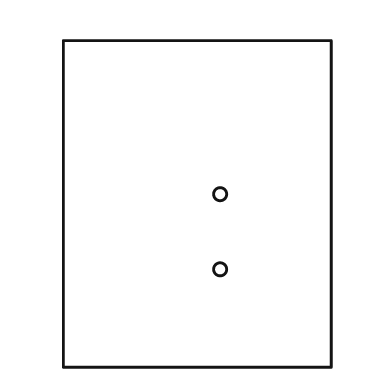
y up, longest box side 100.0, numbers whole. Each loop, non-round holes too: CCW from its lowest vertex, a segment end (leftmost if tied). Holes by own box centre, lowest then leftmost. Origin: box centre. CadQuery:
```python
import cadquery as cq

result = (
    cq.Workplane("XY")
    .moveTo(-41.0, -50.0)
    .lineTo(41.0, -50.0)
    .lineTo(41.0, 50.0)
    .lineTo(-41.0, 50.0)
    .close()
    .moveTo(7.0, -20.0)
    .circle(2.0)
    .moveTo(7.0, 3.0)
    .circle(2.0)
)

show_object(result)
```